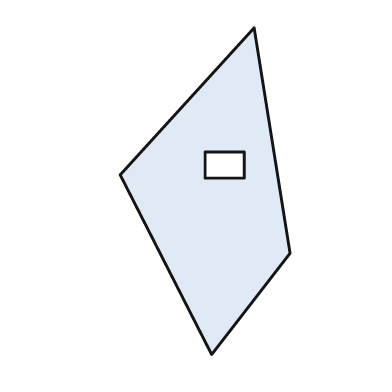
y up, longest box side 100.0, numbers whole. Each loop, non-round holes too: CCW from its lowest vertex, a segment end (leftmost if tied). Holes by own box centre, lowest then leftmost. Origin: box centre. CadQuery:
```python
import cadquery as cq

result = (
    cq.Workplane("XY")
    .moveTo(2.0, -50.0)
    .lineTo(26.0, -19.0)
    .lineTo(15.0, 50.0)
    .lineTo(-26.0, 5.0)
    .close()
    .moveTo(0.0, 4.0)
    .lineTo(12.0, 4.0)
    .lineTo(12.0, 12.0)
    .lineTo(0.0, 12.0)
    .close()
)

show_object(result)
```